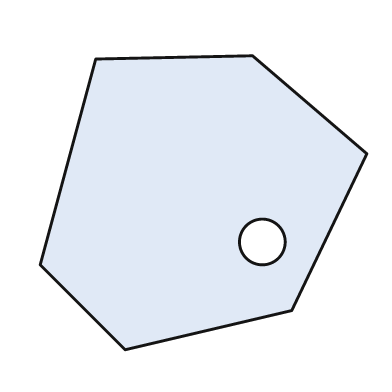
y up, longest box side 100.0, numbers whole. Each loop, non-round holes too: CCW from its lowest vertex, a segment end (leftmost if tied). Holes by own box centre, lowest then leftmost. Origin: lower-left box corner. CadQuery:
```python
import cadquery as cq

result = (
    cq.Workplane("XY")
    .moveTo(26.0, 0.0)
    .lineTo(77.0, 12.0)
    .lineTo(100.0, 60.0)
    .lineTo(65.0, 90.0)
    .lineTo(17.0, 89.0)
    .lineTo(0.0, 26.0)
    .close()
    .moveTo(68.0, 33.0)
    .circle(7.0)
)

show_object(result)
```